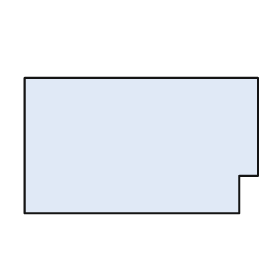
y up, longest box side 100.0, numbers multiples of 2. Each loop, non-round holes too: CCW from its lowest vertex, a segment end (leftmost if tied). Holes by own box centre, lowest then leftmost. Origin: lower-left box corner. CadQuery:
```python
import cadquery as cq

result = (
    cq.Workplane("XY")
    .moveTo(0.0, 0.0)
    .lineTo(92.0, 0.0)
    .lineTo(92.0, 16.0)
    .lineTo(100.0, 16.0)
    .lineTo(100.0, 58.0)
    .lineTo(0.0, 58.0)
    .close()
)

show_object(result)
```